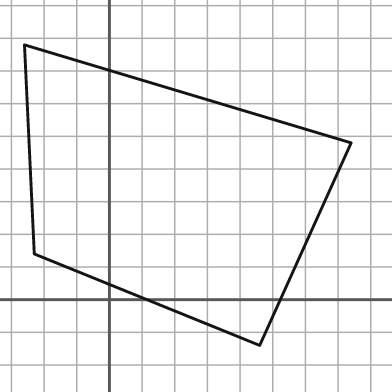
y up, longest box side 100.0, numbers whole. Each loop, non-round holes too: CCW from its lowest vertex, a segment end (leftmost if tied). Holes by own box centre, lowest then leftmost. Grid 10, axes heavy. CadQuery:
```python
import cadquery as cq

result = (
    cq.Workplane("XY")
    .moveTo(46.0, -14.0)
    .lineTo(74.0, 48.0)
    .lineTo(-26.0, 78.0)
    .lineTo(-23.0, 14.0)
    .close()
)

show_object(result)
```